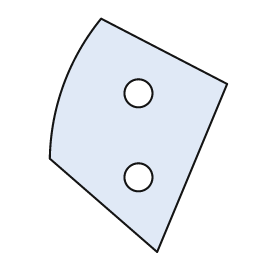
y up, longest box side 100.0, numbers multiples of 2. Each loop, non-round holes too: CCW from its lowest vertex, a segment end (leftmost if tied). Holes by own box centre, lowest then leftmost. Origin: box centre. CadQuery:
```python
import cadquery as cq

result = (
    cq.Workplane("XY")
    .moveTo(8.0, -50.0)
    .lineTo(38.0, 22.0)
    .lineTo(-16.0, 50.0)
    .threePointArc((-32.0, 22.0), (-38.0, -10.0))
    .close()
    .moveTo(0.0, -18.0)
    .circle(6.0)
    .moveTo(0.0, 18.0)
    .circle(6.0)
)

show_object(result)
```